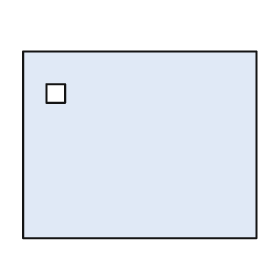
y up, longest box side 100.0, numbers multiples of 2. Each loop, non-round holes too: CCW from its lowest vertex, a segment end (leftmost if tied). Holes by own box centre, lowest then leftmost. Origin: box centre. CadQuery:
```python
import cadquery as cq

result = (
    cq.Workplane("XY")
    .moveTo(-50.0, -40.0)
    .lineTo(50.0, -40.0)
    .lineTo(50.0, 40.0)
    .lineTo(-50.0, 40.0)
    .close()
    .moveTo(-40.0, 18.0)
    .lineTo(-32.0, 18.0)
    .lineTo(-32.0, 26.0)
    .lineTo(-40.0, 26.0)
    .close()
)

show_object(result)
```